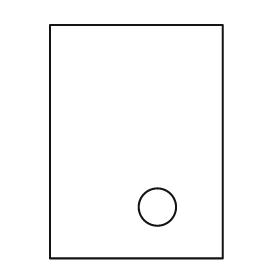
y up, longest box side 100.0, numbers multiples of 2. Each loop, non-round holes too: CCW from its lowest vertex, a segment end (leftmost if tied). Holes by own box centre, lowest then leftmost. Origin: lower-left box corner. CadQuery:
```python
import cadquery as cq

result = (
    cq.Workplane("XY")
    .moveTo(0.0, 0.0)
    .lineTo(74.0, 0.0)
    .lineTo(74.0, 100.0)
    .lineTo(0.0, 100.0)
    .close()
    .moveTo(46.0, 22.0)
    .circle(8.0)
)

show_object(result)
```